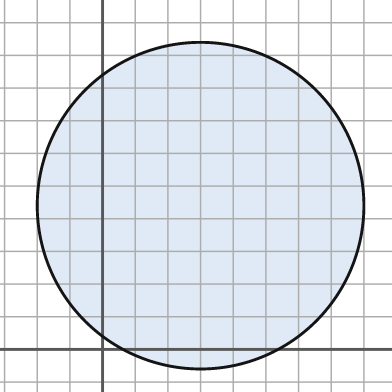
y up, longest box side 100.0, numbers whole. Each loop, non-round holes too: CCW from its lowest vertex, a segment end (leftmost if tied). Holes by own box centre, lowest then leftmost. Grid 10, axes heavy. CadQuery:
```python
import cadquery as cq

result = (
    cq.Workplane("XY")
    .moveTo(30.0, 44.0)
    .circle(50.0)
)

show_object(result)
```